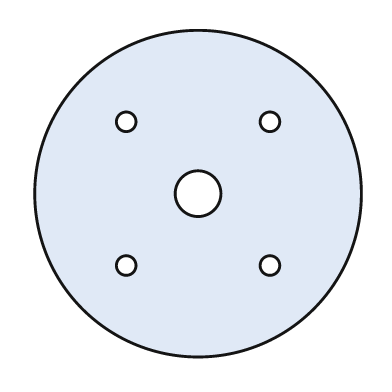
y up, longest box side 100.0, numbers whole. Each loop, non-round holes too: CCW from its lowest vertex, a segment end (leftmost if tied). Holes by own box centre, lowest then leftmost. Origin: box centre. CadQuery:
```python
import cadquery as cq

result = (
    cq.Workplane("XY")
    .moveTo(0.0, 0.0)
    .circle(50.0)
    .moveTo(-22.0, -22.0)
    .circle(3.0)
    .moveTo(22.0, -22.0)
    .circle(3.0)
    .moveTo(0.0, 0.0)
    .circle(7.0)
    .moveTo(-22.0, 22.0)
    .circle(3.0)
    .moveTo(22.0, 22.0)
    .circle(3.0)
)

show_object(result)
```